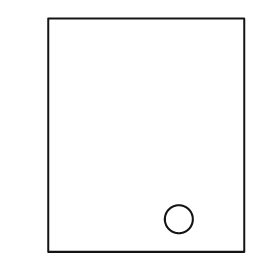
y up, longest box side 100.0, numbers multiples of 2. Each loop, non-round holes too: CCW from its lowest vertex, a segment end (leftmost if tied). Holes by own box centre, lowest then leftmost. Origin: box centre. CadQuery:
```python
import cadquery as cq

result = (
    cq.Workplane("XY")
    .moveTo(-42.0, -50.0)
    .lineTo(42.0, -50.0)
    .lineTo(42.0, 50.0)
    .lineTo(-42.0, 50.0)
    .close()
    .moveTo(14.0, -36.0)
    .circle(6.0)
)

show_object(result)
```